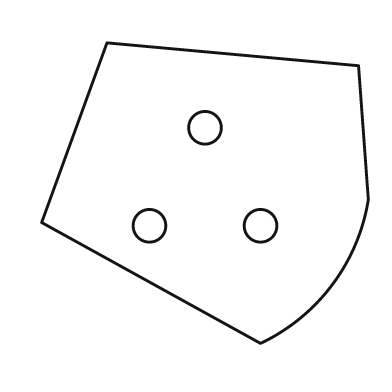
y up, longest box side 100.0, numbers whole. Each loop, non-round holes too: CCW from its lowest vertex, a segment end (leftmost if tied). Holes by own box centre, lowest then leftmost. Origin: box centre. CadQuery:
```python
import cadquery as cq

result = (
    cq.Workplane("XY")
    .moveTo(17.0, -46.0)
    .threePointArc((39.0, -28.0), (50.0, -2.0))
    .lineTo(47.0, 39.0)
    .lineTo(-30.0, 46.0)
    .lineTo(-50.0, -9.0)
    .close()
    .moveTo(-17.0, -10.0)
    .circle(5.0)
    .moveTo(17.0, -10.0)
    .circle(5.0)
    .moveTo(0.0, 20.0)
    .circle(5.0)
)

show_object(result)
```